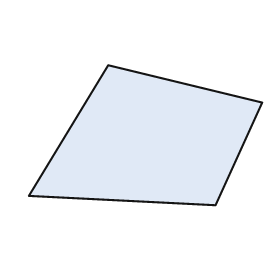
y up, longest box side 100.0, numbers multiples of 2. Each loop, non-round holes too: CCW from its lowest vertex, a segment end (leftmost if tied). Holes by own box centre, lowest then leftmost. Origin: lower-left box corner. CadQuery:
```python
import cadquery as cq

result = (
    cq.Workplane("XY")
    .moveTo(80.0, 0.0)
    .lineTo(100.0, 44.0)
    .lineTo(34.0, 60.0)
    .lineTo(0.0, 4.0)
    .close()
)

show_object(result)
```